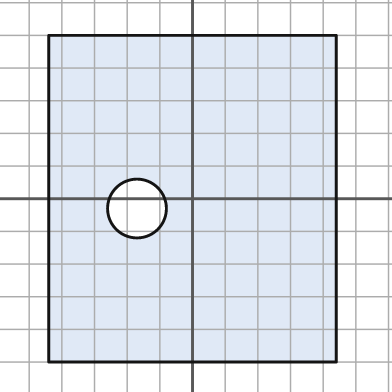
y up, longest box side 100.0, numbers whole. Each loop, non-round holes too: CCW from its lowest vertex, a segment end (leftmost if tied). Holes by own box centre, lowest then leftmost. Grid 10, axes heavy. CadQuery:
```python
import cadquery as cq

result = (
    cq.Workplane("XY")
    .moveTo(-44.0, -50.0)
    .lineTo(44.0, -50.0)
    .lineTo(44.0, 50.0)
    .lineTo(-44.0, 50.0)
    .close()
    .moveTo(-17.0, -3.0)
    .circle(9.0)
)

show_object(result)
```